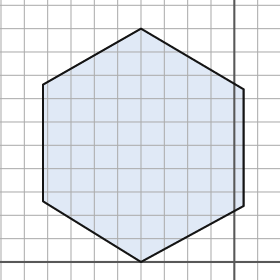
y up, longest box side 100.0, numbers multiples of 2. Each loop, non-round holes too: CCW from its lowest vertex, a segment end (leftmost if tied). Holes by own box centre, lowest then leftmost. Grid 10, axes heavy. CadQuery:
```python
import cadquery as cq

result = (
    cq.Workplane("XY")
    .moveTo(-40.0, 0.0)
    .lineTo(4.0, 24.0)
    .lineTo(4.0, 74.0)
    .lineTo(-40.0, 100.0)
    .lineTo(-82.0, 76.0)
    .lineTo(-82.0, 26.0)
    .close()
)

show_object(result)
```